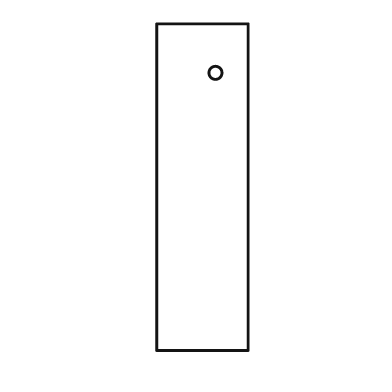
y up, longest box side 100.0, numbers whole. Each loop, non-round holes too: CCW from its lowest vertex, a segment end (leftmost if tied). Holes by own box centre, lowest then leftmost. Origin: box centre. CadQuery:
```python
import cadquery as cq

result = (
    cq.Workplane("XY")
    .moveTo(-14.0, -50.0)
    .lineTo(14.0, -50.0)
    .lineTo(14.0, 50.0)
    .lineTo(-14.0, 50.0)
    .close()
    .moveTo(4.0, 35.0)
    .circle(2.0)
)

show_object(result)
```